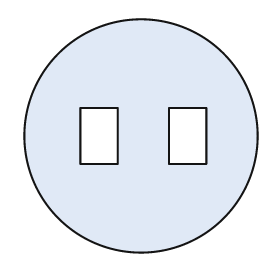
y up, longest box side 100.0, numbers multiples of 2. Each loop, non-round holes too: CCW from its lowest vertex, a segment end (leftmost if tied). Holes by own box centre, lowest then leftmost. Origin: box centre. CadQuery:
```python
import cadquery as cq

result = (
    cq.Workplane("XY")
    .moveTo(0.0, 0.0)
    .circle(50.0)
    .moveTo(-26.0, -12.0)
    .lineTo(-10.0, -12.0)
    .lineTo(-10.0, 12.0)
    .lineTo(-26.0, 12.0)
    .close()
    .moveTo(12.0, -12.0)
    .lineTo(28.0, -12.0)
    .lineTo(28.0, 12.0)
    .lineTo(12.0, 12.0)
    .close()
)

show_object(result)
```